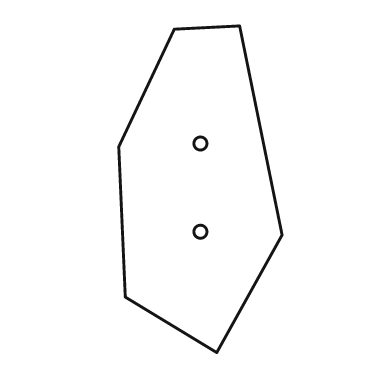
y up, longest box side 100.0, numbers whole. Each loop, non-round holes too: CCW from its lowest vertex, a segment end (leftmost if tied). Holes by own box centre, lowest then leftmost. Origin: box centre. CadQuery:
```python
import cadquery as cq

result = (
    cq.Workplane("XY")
    .moveTo(5.0, -50.0)
    .lineTo(25.0, -14.0)
    .lineTo(12.0, 50.0)
    .lineTo(-8.0, 49.0)
    .lineTo(-25.0, 13.0)
    .lineTo(-23.0, -33.0)
    .close()
    .moveTo(0.0, -13.0)
    .circle(2.0)
    .moveTo(0.0, 14.0)
    .circle(2.0)
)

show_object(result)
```